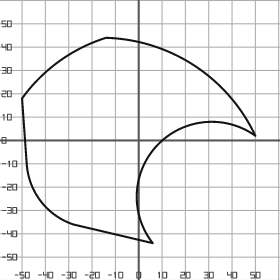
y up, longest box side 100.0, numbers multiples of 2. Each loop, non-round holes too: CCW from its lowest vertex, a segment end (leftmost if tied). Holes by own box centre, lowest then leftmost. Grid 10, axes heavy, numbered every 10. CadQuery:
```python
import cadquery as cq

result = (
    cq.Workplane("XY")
    .moveTo(6.0, -44.0)
    .threePointArc((8.0, -2.0), (50.0, 2.0))
    .threePointArc((24.0, 32.0), (-14.0, 44.0))
    .threePointArc((-34.0, 34.0), (-50.0, 18.0))
    .lineTo(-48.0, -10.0)
    .threePointArc((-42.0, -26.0), (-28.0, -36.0))
    .close()
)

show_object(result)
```